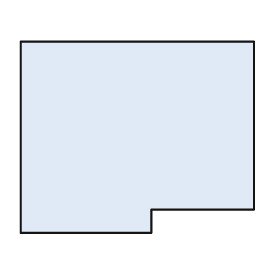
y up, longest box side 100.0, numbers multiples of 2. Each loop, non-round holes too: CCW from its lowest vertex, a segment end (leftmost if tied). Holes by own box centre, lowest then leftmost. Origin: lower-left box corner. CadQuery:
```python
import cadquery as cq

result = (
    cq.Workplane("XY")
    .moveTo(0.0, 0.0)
    .lineTo(56.0, 0.0)
    .lineTo(56.0, 10.0)
    .lineTo(100.0, 10.0)
    .lineTo(100.0, 82.0)
    .lineTo(0.0, 82.0)
    .close()
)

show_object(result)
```